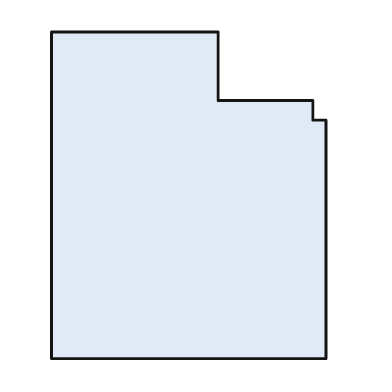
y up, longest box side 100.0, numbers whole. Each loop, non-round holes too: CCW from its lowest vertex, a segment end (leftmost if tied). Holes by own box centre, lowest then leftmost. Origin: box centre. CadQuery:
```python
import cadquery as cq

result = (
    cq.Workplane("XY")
    .moveTo(-42.0, -50.0)
    .lineTo(42.0, -50.0)
    .lineTo(42.0, 23.0)
    .lineTo(38.0, 23.0)
    .lineTo(38.0, 29.0)
    .lineTo(9.0, 29.0)
    .lineTo(9.0, 50.0)
    .lineTo(-42.0, 50.0)
    .close()
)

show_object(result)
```